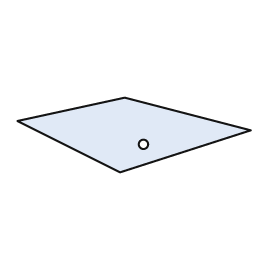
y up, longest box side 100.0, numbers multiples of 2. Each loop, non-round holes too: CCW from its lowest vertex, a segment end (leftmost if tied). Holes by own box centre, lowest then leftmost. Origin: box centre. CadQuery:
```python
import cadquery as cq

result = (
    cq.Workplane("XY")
    .moveTo(-6.0, -16.0)
    .lineTo(50.0, 2.0)
    .lineTo(-4.0, 16.0)
    .lineTo(-50.0, 6.0)
    .close()
    .moveTo(4.0, -4.0)
    .circle(2.0)
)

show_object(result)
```